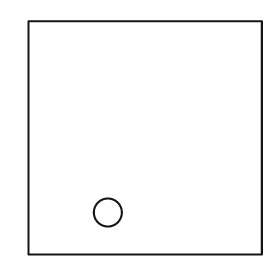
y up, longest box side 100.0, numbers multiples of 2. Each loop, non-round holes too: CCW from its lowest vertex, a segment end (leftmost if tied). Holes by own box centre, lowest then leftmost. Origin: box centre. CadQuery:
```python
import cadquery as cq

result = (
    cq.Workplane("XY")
    .moveTo(-50.0, -50.0)
    .lineTo(50.0, -50.0)
    .lineTo(50.0, 50.0)
    .lineTo(-50.0, 50.0)
    .close()
    .moveTo(-16.0, -32.0)
    .circle(6.0)
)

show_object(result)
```